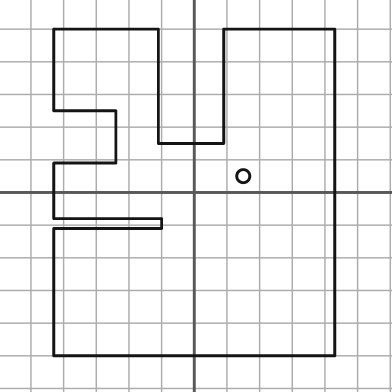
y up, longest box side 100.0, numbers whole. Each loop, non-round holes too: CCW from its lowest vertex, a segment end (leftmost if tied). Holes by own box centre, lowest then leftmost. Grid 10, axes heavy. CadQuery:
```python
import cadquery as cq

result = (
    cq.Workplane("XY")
    .moveTo(-43.0, -50.0)
    .lineTo(43.0, -50.0)
    .lineTo(43.0, 50.0)
    .lineTo(9.0, 50.0)
    .lineTo(9.0, 15.0)
    .lineTo(-11.0, 15.0)
    .lineTo(-11.0, 50.0)
    .lineTo(-43.0, 50.0)
    .lineTo(-43.0, 25.0)
    .lineTo(-24.0, 25.0)
    .lineTo(-24.0, 9.0)
    .lineTo(-43.0, 9.0)
    .lineTo(-43.0, -8.0)
    .lineTo(-10.0, -8.0)
    .lineTo(-10.0, -11.0)
    .lineTo(-43.0, -11.0)
    .close()
    .moveTo(15.0, 5.0)
    .circle(2.0)
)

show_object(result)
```